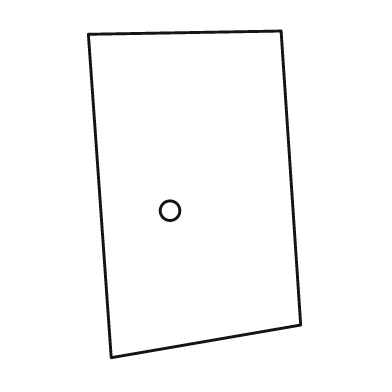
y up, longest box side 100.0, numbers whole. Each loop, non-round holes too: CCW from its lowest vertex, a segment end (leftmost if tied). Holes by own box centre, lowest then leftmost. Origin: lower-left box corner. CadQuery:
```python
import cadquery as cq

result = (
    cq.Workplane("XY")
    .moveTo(7.0, 0.0)
    .lineTo(65.0, 10.0)
    .lineTo(59.0, 100.0)
    .lineTo(0.0, 99.0)
    .close()
    .moveTo(25.0, 45.0)
    .circle(3.0)
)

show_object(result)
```